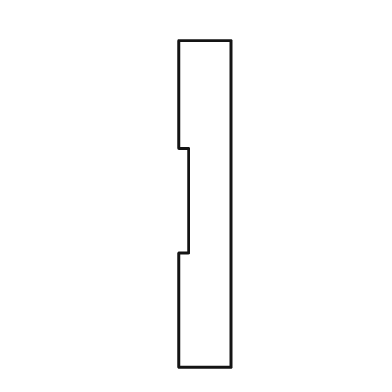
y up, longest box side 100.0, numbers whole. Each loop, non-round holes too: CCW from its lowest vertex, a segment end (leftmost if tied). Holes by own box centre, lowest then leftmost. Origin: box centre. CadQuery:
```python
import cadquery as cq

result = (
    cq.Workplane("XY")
    .moveTo(-8.0, -50.0)
    .lineTo(8.0, -50.0)
    .lineTo(8.0, 50.0)
    .lineTo(-8.0, 50.0)
    .lineTo(-8.0, 17.0)
    .lineTo(-5.0, 17.0)
    .lineTo(-5.0, -15.0)
    .lineTo(-8.0, -15.0)
    .close()
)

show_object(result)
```